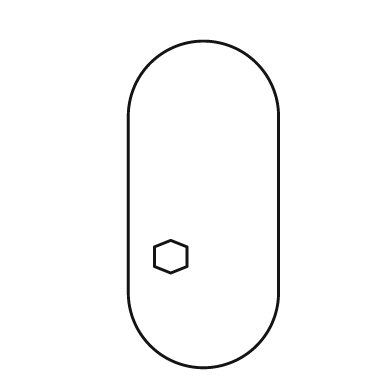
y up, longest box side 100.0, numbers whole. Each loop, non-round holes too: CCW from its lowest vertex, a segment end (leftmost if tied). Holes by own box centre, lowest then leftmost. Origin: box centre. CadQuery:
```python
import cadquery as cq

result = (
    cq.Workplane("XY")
    .moveTo(-23.0, -27.0)
    .threePointArc((0.0, -50.0), (23.0, -27.0))
    .lineTo(23.0, 27.0)
    .threePointArc((0.0, 50.0), (-23.0, 27.0))
    .close()
    .moveTo(-10.0, -21.0)
    .lineTo(-5.0, -19.0)
    .lineTo(-5.0, -13.0)
    .lineTo(-10.0, -11.0)
    .lineTo(-15.0, -13.0)
    .lineTo(-15.0, -19.0)
    .close()
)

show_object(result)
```